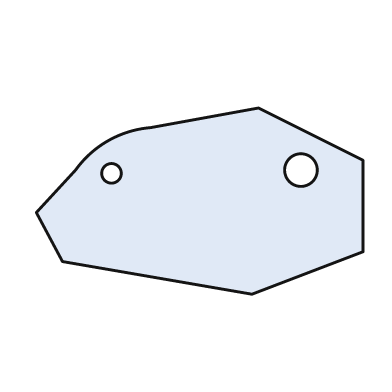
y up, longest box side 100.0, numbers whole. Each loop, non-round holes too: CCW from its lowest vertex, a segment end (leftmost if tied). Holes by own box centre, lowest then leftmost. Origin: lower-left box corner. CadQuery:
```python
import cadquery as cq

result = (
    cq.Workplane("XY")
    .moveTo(66.0, 0.0)
    .lineTo(100.0, 13.0)
    .lineTo(100.0, 41.0)
    .lineTo(68.0, 57.0)
    .lineTo(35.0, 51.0)
    .threePointArc((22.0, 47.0), (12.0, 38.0))
    .lineTo(0.0, 25.0)
    .lineTo(8.0, 10.0)
    .close()
    .moveTo(23.0, 37.0)
    .circle(3.0)
    .moveTo(81.0, 38.0)
    .circle(5.0)
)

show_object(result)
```